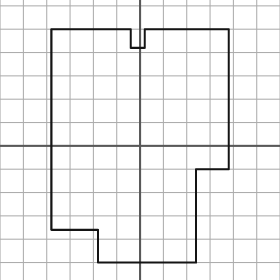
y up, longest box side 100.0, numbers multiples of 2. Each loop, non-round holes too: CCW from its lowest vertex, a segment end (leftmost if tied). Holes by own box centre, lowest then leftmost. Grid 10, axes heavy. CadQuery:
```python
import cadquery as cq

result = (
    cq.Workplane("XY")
    .moveTo(-18.0, -50.0)
    .lineTo(24.0, -50.0)
    .lineTo(24.0, -10.0)
    .lineTo(38.0, -10.0)
    .lineTo(38.0, 50.0)
    .lineTo(2.0, 50.0)
    .lineTo(2.0, 42.0)
    .lineTo(-4.0, 42.0)
    .lineTo(-4.0, 50.0)
    .lineTo(-38.0, 50.0)
    .lineTo(-38.0, -36.0)
    .lineTo(-18.0, -36.0)
    .close()
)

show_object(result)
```